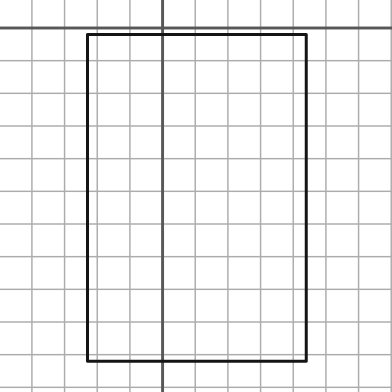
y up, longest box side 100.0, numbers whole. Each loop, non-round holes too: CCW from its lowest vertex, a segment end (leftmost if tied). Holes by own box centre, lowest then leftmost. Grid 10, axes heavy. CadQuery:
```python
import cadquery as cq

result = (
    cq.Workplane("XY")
    .moveTo(-23.0, -102.0)
    .lineTo(44.0, -102.0)
    .lineTo(44.0, -2.0)
    .lineTo(-23.0, -2.0)
    .close()
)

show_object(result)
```